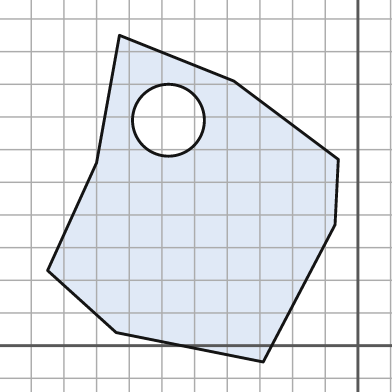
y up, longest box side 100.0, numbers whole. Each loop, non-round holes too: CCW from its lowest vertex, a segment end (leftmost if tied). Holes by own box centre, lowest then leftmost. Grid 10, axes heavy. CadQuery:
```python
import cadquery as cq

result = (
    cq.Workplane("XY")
    .moveTo(-29.0, -5.0)
    .lineTo(-7.0, 37.0)
    .lineTo(-6.0, 57.0)
    .lineTo(-38.0, 81.0)
    .lineTo(-73.0, 95.0)
    .lineTo(-80.0, 56.0)
    .lineTo(-95.0, 23.0)
    .lineTo(-74.0, 4.0)
    .close()
    .moveTo(-58.0, 69.0)
    .circle(11.0)
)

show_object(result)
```